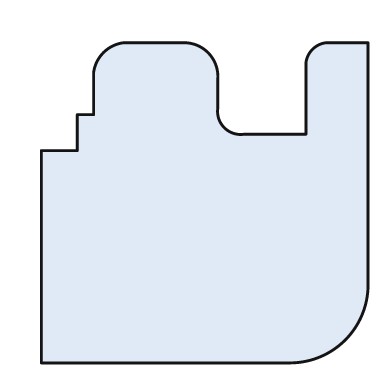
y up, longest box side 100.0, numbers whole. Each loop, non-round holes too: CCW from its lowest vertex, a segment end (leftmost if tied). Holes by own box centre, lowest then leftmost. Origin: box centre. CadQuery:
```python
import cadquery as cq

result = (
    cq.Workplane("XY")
    .moveTo(-50.0, -49.0)
    .lineTo(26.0, -49.0)
    .threePointArc((43.0, -42.0), (50.0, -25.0))
    .lineTo(50.0, 49.0)
    .lineTo(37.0, 49.0)
    .threePointArc((33.0, 47.0), (31.0, 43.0))
    .lineTo(31.0, 21.0)
    .lineTo(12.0, 21.0)
    .threePointArc((6.0, 23.0), (4.0, 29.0))
    .lineTo(4.0, 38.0)
    .threePointArc((1.0, 46.0), (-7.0, 49.0))
    .lineTo(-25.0, 49.0)
    .threePointArc((-31.0, 46.0), (-34.0, 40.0))
    .lineTo(-34.0, 27.0)
    .lineTo(-39.0, 27.0)
    .lineTo(-39.0, 16.0)
    .lineTo(-50.0, 16.0)
    .close()
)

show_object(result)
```